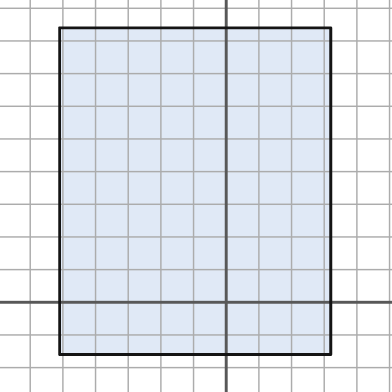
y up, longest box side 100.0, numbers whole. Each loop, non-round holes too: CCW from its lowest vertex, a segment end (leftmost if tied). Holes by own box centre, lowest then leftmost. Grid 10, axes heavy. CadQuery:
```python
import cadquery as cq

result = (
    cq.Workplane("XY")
    .moveTo(-51.0, -16.0)
    .lineTo(32.0, -16.0)
    .lineTo(32.0, 84.0)
    .lineTo(-51.0, 84.0)
    .close()
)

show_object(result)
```